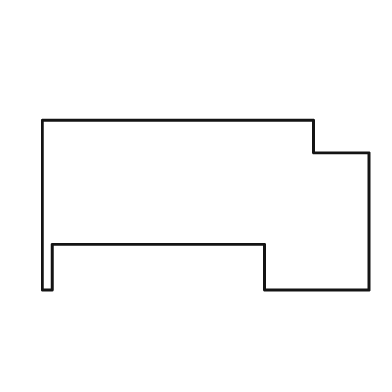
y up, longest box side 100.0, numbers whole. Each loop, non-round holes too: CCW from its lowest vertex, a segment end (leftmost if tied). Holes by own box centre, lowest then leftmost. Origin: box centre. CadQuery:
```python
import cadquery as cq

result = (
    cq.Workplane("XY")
    .moveTo(-50.0, -26.0)
    .lineTo(-47.0, -26.0)
    .lineTo(-47.0, -12.0)
    .lineTo(18.0, -12.0)
    .lineTo(18.0, -26.0)
    .lineTo(50.0, -26.0)
    .lineTo(50.0, 16.0)
    .lineTo(33.0, 16.0)
    .lineTo(33.0, 26.0)
    .lineTo(-50.0, 26.0)
    .close()
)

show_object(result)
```